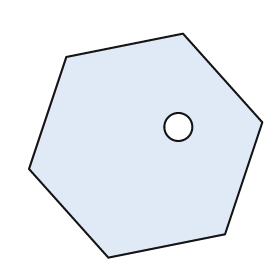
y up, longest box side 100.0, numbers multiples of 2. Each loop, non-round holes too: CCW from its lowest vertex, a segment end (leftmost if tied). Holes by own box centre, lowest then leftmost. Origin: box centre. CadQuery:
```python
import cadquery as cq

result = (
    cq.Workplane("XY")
    .moveTo(-16.0, -48.0)
    .lineTo(34.0, -38.0)
    .lineTo(50.0, 10.0)
    .lineTo(16.0, 48.0)
    .lineTo(-34.0, 38.0)
    .lineTo(-50.0, -10.0)
    .close()
    .moveTo(14.0, 8.0)
    .circle(6.0)
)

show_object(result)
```